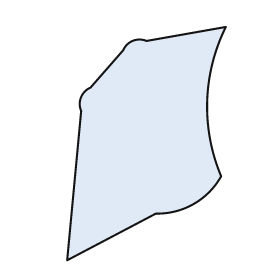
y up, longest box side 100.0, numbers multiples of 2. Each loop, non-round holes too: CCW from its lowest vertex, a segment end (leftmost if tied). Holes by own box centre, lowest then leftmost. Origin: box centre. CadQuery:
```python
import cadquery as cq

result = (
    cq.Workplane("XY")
    .moveTo(-34.0, -50.0)
    .lineTo(4.0, -30.0)
    .threePointArc((20.0, -26.0), (32.0, -14.0))
    .threePointArc((26.0, 18.0), (34.0, 50.0))
    .lineTo(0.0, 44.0)
    .threePointArc((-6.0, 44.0), (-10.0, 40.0))
    .lineTo(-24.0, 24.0)
    .threePointArc((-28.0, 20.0), (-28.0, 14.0))
    .close()
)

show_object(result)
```